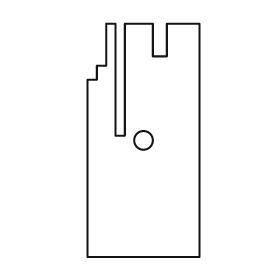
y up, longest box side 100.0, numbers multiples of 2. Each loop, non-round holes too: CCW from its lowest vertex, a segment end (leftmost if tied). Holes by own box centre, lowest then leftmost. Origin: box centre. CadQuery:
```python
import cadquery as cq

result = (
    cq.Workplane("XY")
    .moveTo(-24.0, -50.0)
    .lineTo(24.0, -50.0)
    .lineTo(24.0, 50.0)
    .lineTo(10.0, 50.0)
    .lineTo(10.0, 36.0)
    .lineTo(4.0, 36.0)
    .lineTo(4.0, 50.0)
    .lineTo(-8.0, 50.0)
    .lineTo(-8.0, 2.0)
    .lineTo(-12.0, 2.0)
    .lineTo(-12.0, 50.0)
    .lineTo(-16.0, 50.0)
    .lineTo(-16.0, 32.0)
    .lineTo(-20.0, 32.0)
    .lineTo(-20.0, 26.0)
    .lineTo(-24.0, 26.0)
    .close()
    .moveTo(0.0, 0.0)
    .circle(4.0)
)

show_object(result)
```